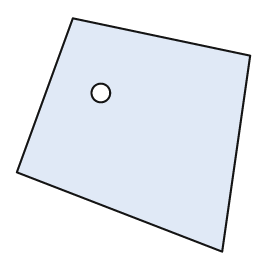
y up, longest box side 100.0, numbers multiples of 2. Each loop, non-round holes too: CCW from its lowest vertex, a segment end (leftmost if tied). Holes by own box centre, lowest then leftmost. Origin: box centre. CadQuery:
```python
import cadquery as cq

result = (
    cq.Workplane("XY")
    .moveTo(38.0, -50.0)
    .lineTo(50.0, 34.0)
    .lineTo(-26.0, 50.0)
    .lineTo(-50.0, -16.0)
    .close()
    .moveTo(-14.0, 18.0)
    .circle(4.0)
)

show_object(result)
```